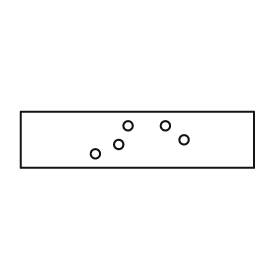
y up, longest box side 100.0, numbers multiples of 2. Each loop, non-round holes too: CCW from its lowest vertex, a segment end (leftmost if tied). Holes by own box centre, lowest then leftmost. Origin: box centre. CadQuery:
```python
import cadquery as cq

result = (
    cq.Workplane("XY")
    .moveTo(-50.0, -12.0)
    .lineTo(50.0, -12.0)
    .lineTo(50.0, 12.0)
    .lineTo(-50.0, 12.0)
    .close()
    .moveTo(-18.0, -6.0)
    .circle(2.0)
    .moveTo(-8.0, -2.0)
    .circle(2.0)
    .moveTo(20.0, 0.0)
    .circle(2.0)
    .moveTo(-4.0, 6.0)
    .circle(2.0)
    .moveTo(12.0, 6.0)
    .circle(2.0)
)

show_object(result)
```